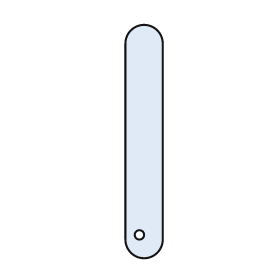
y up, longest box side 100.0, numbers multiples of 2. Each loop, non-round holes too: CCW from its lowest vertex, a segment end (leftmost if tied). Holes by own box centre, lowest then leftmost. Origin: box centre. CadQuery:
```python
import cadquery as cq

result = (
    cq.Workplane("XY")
    .moveTo(-8.0, -42.0)
    .threePointArc((0.0, -50.0), (8.0, -42.0))
    .lineTo(8.0, 42.0)
    .threePointArc((0.0, 50.0), (-8.0, 42.0))
    .close()
    .moveTo(-2.0, -40.0)
    .circle(2.0)
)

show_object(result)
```